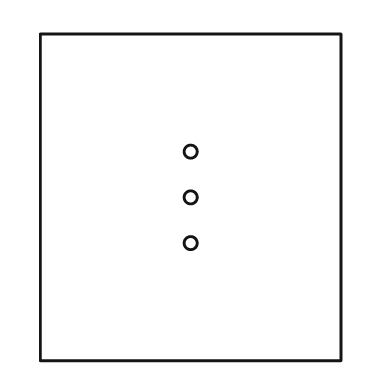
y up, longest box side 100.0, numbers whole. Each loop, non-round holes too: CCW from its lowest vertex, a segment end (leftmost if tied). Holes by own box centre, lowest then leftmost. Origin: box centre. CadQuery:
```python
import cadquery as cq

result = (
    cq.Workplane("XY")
    .moveTo(-46.0, -50.0)
    .lineTo(46.0, -50.0)
    .lineTo(46.0, 50.0)
    .lineTo(-46.0, 50.0)
    .close()
    .moveTo(0.0, -14.0)
    .circle(2.0)
    .moveTo(0.0, 0.0)
    .circle(2.0)
    .moveTo(0.0, 14.0)
    .circle(2.0)
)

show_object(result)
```